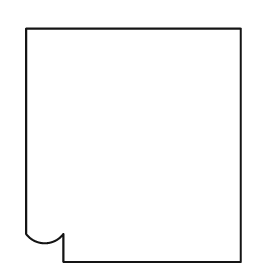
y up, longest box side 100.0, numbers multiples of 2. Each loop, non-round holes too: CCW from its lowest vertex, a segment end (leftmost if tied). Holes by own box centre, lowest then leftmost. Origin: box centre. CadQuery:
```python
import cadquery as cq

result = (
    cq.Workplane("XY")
    .moveTo(-30.0, -50.0)
    .lineTo(46.0, -50.0)
    .lineTo(46.0, 50.0)
    .lineTo(-46.0, 50.0)
    .lineTo(-46.0, -38.0)
    .threePointArc((-38.0, -42.0), (-30.0, -38.0))
    .close()
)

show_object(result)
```